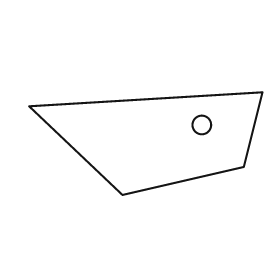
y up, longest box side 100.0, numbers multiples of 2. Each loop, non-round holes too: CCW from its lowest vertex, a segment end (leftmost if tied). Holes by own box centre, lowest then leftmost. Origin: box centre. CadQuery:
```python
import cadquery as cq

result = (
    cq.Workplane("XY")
    .moveTo(-10.0, -22.0)
    .lineTo(42.0, -10.0)
    .lineTo(50.0, 22.0)
    .lineTo(-50.0, 16.0)
    .close()
    .moveTo(24.0, 8.0)
    .circle(4.0)
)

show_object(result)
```